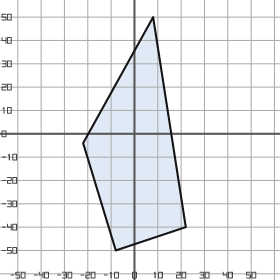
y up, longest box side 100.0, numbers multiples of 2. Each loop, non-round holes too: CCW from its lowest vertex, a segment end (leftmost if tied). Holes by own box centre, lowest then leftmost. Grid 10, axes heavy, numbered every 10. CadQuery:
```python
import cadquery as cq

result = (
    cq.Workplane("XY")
    .moveTo(-8.0, -50.0)
    .lineTo(22.0, -40.0)
    .lineTo(8.0, 50.0)
    .lineTo(-22.0, -4.0)
    .close()
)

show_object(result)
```